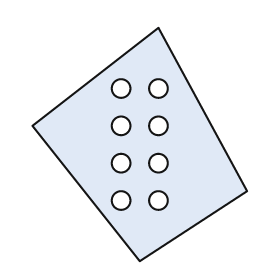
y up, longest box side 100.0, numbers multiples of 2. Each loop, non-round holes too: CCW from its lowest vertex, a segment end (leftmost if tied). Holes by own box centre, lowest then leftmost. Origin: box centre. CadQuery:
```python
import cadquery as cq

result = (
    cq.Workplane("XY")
    .moveTo(0.0, -50.0)
    .lineTo(46.0, -20.0)
    .lineTo(8.0, 50.0)
    .lineTo(-46.0, 8.0)
    .close()
    .moveTo(-8.0, -24.0)
    .circle(4.0)
    .moveTo(8.0, -24.0)
    .circle(4.0)
    .moveTo(-8.0, -8.0)
    .circle(4.0)
    .moveTo(8.0, -8.0)
    .circle(4.0)
    .moveTo(-8.0, 8.0)
    .circle(4.0)
    .moveTo(8.0, 8.0)
    .circle(4.0)
    .moveTo(-8.0, 24.0)
    .circle(4.0)
    .moveTo(8.0, 24.0)
    .circle(4.0)
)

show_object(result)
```